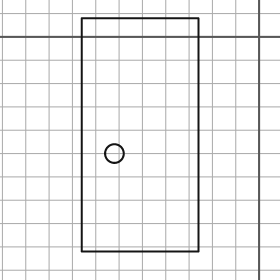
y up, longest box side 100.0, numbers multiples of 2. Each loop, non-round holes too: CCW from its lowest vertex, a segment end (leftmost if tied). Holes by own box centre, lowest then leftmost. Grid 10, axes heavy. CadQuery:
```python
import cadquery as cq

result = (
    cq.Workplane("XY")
    .moveTo(-76.0, -92.0)
    .lineTo(-26.0, -92.0)
    .lineTo(-26.0, 8.0)
    .lineTo(-76.0, 8.0)
    .close()
    .moveTo(-62.0, -50.0)
    .circle(4.0)
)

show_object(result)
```